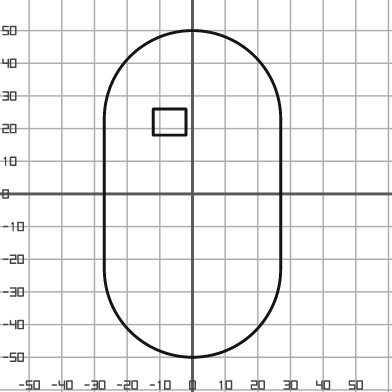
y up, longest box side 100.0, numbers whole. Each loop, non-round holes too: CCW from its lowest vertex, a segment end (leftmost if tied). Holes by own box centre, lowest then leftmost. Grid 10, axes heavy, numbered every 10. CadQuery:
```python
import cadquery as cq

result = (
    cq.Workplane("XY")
    .moveTo(-27.0, -23.0)
    .threePointArc((0.0, -50.0), (27.0, -23.0))
    .lineTo(27.0, 23.0)
    .threePointArc((0.0, 50.0), (-27.0, 23.0))
    .close()
    .moveTo(-12.0, 18.0)
    .lineTo(-2.0, 18.0)
    .lineTo(-2.0, 26.0)
    .lineTo(-12.0, 26.0)
    .close()
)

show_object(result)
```